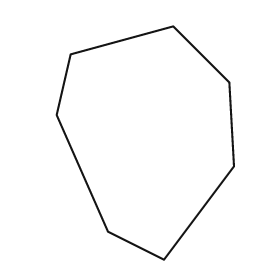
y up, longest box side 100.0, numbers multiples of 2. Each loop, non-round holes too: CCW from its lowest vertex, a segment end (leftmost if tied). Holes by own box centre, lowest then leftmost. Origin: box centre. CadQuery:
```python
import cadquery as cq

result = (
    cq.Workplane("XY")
    .moveTo(8.0, -50.0)
    .lineTo(38.0, -10.0)
    .lineTo(36.0, 26.0)
    .lineTo(12.0, 50.0)
    .lineTo(-32.0, 38.0)
    .lineTo(-38.0, 12.0)
    .lineTo(-16.0, -38.0)
    .close()
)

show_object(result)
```